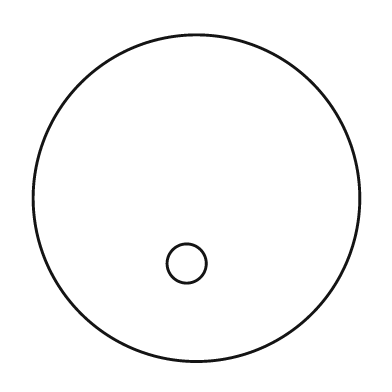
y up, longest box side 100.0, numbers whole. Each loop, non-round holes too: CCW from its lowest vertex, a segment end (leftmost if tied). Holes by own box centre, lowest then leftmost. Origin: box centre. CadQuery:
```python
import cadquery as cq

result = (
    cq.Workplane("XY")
    .moveTo(0.0, 0.0)
    .circle(50.0)
    .moveTo(-3.0, -20.0)
    .circle(6.0)
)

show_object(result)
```